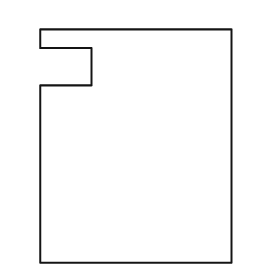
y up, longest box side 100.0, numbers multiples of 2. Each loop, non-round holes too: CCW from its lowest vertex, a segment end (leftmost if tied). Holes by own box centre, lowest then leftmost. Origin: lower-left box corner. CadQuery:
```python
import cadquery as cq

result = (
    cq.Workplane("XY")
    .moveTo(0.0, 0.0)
    .lineTo(82.0, 0.0)
    .lineTo(82.0, 100.0)
    .lineTo(0.0, 100.0)
    .lineTo(0.0, 92.0)
    .lineTo(22.0, 92.0)
    .lineTo(22.0, 76.0)
    .lineTo(0.0, 76.0)
    .close()
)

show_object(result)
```